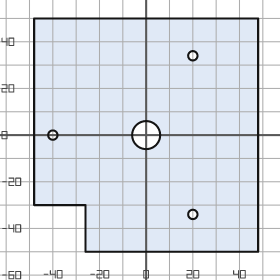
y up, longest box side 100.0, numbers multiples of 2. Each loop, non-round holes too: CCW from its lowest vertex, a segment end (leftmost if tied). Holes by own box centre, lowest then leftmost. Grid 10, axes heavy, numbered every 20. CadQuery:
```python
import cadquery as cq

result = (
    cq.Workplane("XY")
    .moveTo(-26.0, -50.0)
    .lineTo(48.0, -50.0)
    .lineTo(48.0, 50.0)
    .lineTo(-48.0, 50.0)
    .lineTo(-48.0, -30.0)
    .lineTo(-26.0, -30.0)
    .close()
    .moveTo(20.0, -34.0)
    .circle(2.0)
    .moveTo(-40.0, 0.0)
    .circle(2.0)
    .moveTo(0.0, 0.0)
    .circle(6.0)
    .moveTo(20.0, 34.0)
    .circle(2.0)
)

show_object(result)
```